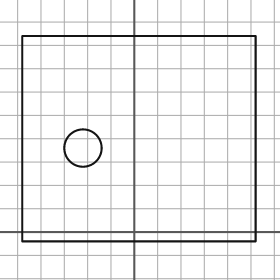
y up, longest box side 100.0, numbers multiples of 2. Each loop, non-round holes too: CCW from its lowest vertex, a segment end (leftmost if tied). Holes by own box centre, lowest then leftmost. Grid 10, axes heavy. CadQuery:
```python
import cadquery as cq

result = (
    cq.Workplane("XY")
    .moveTo(-48.0, -4.0)
    .lineTo(52.0, -4.0)
    .lineTo(52.0, 84.0)
    .lineTo(-48.0, 84.0)
    .close()
    .moveTo(-22.0, 36.0)
    .circle(8.0)
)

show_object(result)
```